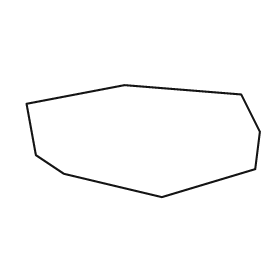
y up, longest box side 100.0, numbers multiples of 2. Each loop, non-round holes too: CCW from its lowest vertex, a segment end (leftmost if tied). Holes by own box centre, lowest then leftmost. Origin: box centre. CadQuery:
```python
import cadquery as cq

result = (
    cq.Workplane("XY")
    .moveTo(8.0, -24.0)
    .lineTo(48.0, -12.0)
    .lineTo(50.0, 4.0)
    .lineTo(42.0, 20.0)
    .lineTo(-8.0, 24.0)
    .lineTo(-50.0, 16.0)
    .lineTo(-46.0, -6.0)
    .lineTo(-34.0, -14.0)
    .close()
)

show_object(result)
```